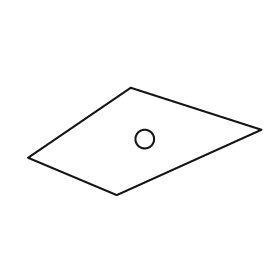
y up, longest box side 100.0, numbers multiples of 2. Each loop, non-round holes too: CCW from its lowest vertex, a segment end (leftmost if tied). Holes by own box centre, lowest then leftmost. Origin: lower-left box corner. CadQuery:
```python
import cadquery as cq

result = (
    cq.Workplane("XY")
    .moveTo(38.0, 0.0)
    .lineTo(100.0, 28.0)
    .lineTo(44.0, 46.0)
    .lineTo(0.0, 16.0)
    .close()
    .moveTo(50.0, 24.0)
    .circle(4.0)
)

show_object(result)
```